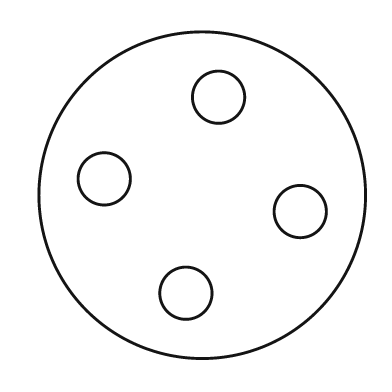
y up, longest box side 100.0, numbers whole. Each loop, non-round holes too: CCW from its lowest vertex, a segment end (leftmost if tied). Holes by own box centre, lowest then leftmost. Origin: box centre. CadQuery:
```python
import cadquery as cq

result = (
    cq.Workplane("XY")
    .moveTo(0.0, 0.0)
    .circle(50.0)
    .moveTo(-5.0, -30.0)
    .circle(8.0)
    .moveTo(30.0, -5.0)
    .circle(8.0)
    .moveTo(-30.0, 5.0)
    .circle(8.0)
    .moveTo(5.0, 30.0)
    .circle(8.0)
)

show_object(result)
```